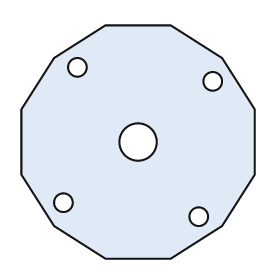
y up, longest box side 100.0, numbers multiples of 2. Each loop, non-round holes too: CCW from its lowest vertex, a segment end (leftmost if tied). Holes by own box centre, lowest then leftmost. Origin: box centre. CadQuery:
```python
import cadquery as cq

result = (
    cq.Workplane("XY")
    .moveTo(-14.0, -50.0)
    .lineTo(14.0, -50.0)
    .lineTo(36.0, -36.0)
    .lineTo(50.0, -14.0)
    .lineTo(50.0, 14.0)
    .lineTo(36.0, 36.0)
    .lineTo(14.0, 50.0)
    .lineTo(-14.0, 50.0)
    .lineTo(-36.0, 36.0)
    .lineTo(-50.0, 14.0)
    .lineTo(-50.0, -14.0)
    .lineTo(-36.0, -36.0)
    .close()
    .moveTo(26.0, -32.0)
    .circle(4.0)
    .moveTo(-32.0, -26.0)
    .circle(4.0)
    .moveTo(0.0, 0.0)
    .circle(8.0)
    .moveTo(32.0, 26.0)
    .circle(4.0)
    .moveTo(-26.0, 32.0)
    .circle(4.0)
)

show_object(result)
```